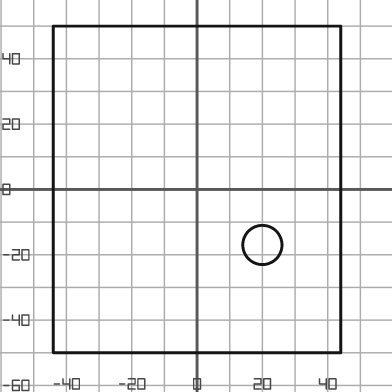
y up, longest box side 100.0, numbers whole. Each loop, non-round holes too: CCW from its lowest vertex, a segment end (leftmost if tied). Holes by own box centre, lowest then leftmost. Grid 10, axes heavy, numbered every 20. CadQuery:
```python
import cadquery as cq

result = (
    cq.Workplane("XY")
    .moveTo(-44.0, -50.0)
    .lineTo(44.0, -50.0)
    .lineTo(44.0, 50.0)
    .lineTo(-44.0, 50.0)
    .close()
    .moveTo(20.0, -17.0)
    .circle(6.0)
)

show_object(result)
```